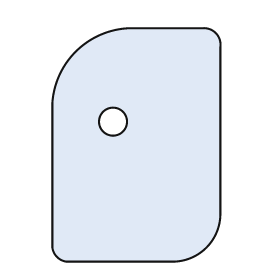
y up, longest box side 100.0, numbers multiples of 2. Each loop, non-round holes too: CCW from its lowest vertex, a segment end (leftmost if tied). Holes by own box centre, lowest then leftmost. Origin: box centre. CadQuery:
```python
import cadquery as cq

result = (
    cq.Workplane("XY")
    .moveTo(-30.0, -50.0)
    .lineTo(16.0, -50.0)
    .threePointArc((30.0, -44.0), (36.0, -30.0))
    .lineTo(36.0, 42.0)
    .threePointArc((34.0, 48.0), (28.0, 50.0))
    .lineTo(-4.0, 50.0)
    .threePointArc((-26.0, 40.0), (-36.0, 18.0))
    .lineTo(-36.0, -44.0)
    .threePointArc((-34.0, -48.0), (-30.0, -50.0))
    .close()
    .moveTo(-10.0, 10.0)
    .circle(6.0)
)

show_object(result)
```